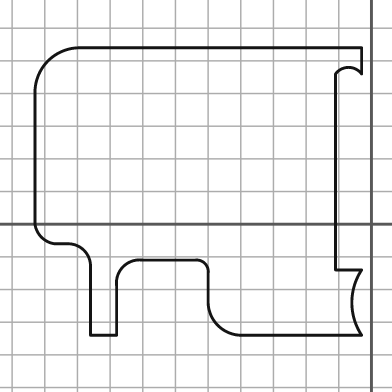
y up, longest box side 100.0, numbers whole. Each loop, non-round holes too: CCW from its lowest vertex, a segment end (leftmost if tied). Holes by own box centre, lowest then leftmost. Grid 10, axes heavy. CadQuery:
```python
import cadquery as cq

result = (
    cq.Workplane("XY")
    .moveTo(-86.0, -34.0)
    .lineTo(-78.0, -34.0)
    .lineTo(-78.0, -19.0)
    .threePointArc((-76.0, -13.0), (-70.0, -11.0))
    .lineTo(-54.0, -11.0)
    .threePointArc((-51.0, -12.0), (-50.0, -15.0))
    .lineTo(-50.0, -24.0)
    .threePointArc((-47.0, -31.0), (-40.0, -34.0))
    .lineTo(-3.0, -34.0)
    .threePointArc((-6.0, -24.0), (-3.0, -14.0))
    .lineTo(-11.0, -14.0)
    .lineTo(-11.0, 46.0)
    .threePointArc((-7.0, 48.0), (-3.0, 46.0))
    .lineTo(-3.0, 54.0)
    .lineTo(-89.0, 54.0)
    .threePointArc((-99.0, 50.0), (-103.0, 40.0))
    .lineTo(-103.0, 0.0)
    .threePointArc((-101.0, -4.0), (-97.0, -6.0))
    .lineTo(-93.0, -6.0)
    .threePointArc((-88.0, -8.0), (-86.0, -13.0))
    .close()
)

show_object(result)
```